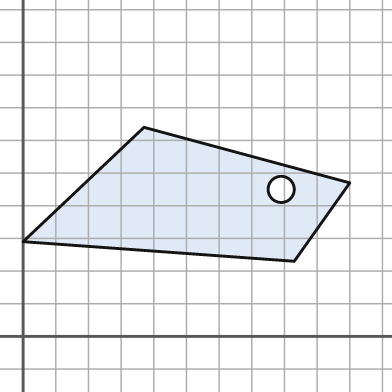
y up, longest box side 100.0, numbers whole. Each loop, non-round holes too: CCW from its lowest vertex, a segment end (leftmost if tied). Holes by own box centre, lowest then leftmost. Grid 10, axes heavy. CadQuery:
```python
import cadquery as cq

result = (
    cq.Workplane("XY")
    .moveTo(83.0, 23.0)
    .lineTo(100.0, 47.0)
    .lineTo(37.0, 64.0)
    .lineTo(0.0, 29.0)
    .close()
    .moveTo(79.0, 45.0)
    .circle(4.0)
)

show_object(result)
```